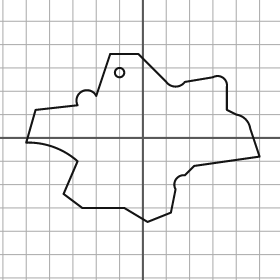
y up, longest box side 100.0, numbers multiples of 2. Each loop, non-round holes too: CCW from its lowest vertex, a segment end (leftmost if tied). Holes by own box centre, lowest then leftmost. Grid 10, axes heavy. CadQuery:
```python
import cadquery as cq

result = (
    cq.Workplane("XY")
    .moveTo(2.0, -36.0)
    .lineTo(12.0, -32.0)
    .lineTo(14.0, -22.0)
    .threePointArc((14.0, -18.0), (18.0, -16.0))
    .lineTo(22.0, -12.0)
    .lineTo(50.0, -8.0)
    .lineTo(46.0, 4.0)
    .threePointArc((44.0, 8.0), (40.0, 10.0))
    .lineTo(36.0, 12.0)
    .lineTo(36.0, 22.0)
    .threePointArc((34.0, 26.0), (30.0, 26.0))
    .lineTo(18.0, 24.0)
    .threePointArc((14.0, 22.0), (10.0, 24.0))
    .lineTo(-2.0, 36.0)
    .lineTo(-14.0, 36.0)
    .lineTo(-20.0, 18.0)
    .threePointArc((-26.0, 20.0), (-28.0, 14.0))
    .lineTo(-46.0, 12.0)
    .lineTo(-50.0, -2.0)
    .threePointArc((-38.0, -4.0), (-28.0, -10.0))
    .lineTo(-34.0, -24.0)
    .lineTo(-26.0, -30.0)
    .lineTo(-8.0, -30.0)
    .close()
    .moveTo(-10.0, 28.0)
    .circle(2.0)
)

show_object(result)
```